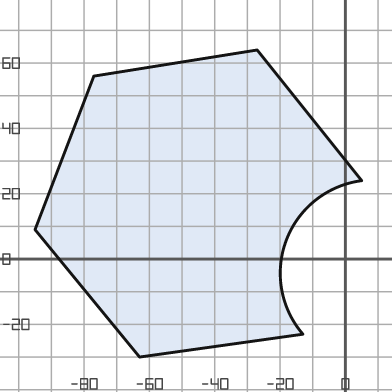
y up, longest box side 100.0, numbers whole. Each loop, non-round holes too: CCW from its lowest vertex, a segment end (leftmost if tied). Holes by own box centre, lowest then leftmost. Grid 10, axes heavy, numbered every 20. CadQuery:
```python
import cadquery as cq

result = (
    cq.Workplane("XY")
    .moveTo(-63.0, -30.0)
    .lineTo(-13.0, -23.0)
    .threePointArc((-18.0, 6.0), (5.0, 24.0))
    .lineTo(-27.0, 64.0)
    .lineTo(-77.0, 56.0)
    .lineTo(-95.0, 9.0)
    .close()
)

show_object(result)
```